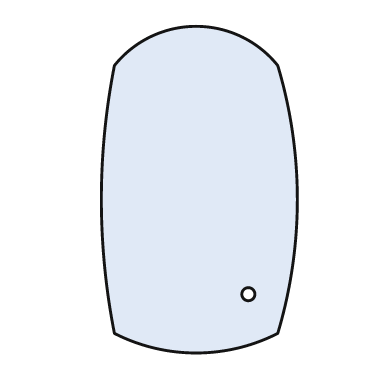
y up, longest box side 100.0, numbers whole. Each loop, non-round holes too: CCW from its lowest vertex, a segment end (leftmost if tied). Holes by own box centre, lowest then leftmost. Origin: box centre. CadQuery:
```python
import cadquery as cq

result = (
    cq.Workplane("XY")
    .moveTo(-26.0, -44.0)
    .threePointArc((-1.0, -50.0), (24.0, -44.0))
    .threePointArc((30.0, -3.0), (24.0, 38.0))
    .threePointArc((-1.0, 50.0), (-26.0, 38.0))
    .threePointArc((-30.0, -3.0), (-26.0, -44.0))
    .close()
    .moveTo(15.0, -32.0)
    .circle(2.0)
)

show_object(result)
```